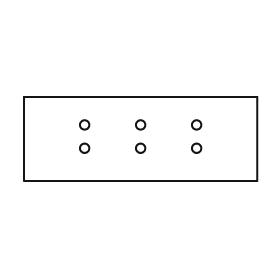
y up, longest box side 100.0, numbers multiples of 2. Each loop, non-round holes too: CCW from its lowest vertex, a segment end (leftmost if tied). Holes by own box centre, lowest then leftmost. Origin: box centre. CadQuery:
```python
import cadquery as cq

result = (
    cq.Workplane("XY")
    .moveTo(-50.0, -18.0)
    .lineTo(50.0, -18.0)
    .lineTo(50.0, 18.0)
    .lineTo(-50.0, 18.0)
    .close()
    .moveTo(-24.0, -4.0)
    .circle(2.0)
    .moveTo(0.0, -4.0)
    .circle(2.0)
    .moveTo(24.0, -4.0)
    .circle(2.0)
    .moveTo(-24.0, 6.0)
    .circle(2.0)
    .moveTo(0.0, 6.0)
    .circle(2.0)
    .moveTo(24.0, 6.0)
    .circle(2.0)
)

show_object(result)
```